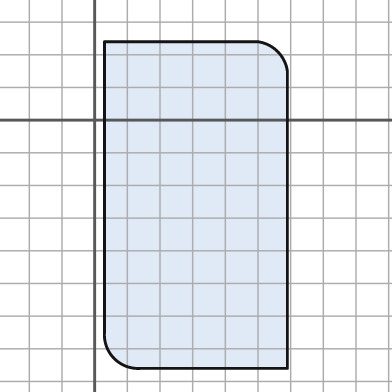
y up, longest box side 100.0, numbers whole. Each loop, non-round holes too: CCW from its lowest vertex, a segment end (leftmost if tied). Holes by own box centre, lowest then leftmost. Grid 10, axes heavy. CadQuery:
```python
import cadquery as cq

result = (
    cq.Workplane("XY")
    .moveTo(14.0, -76.0)
    .lineTo(59.0, -76.0)
    .lineTo(59.0, 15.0)
    .threePointArc((56.0, 21.0), (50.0, 24.0))
    .lineTo(3.0, 24.0)
    .lineTo(3.0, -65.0)
    .threePointArc((6.0, -73.0), (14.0, -76.0))
    .close()
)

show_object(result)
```